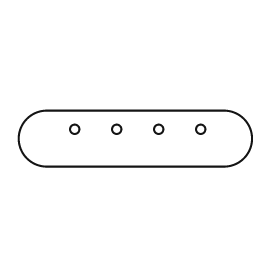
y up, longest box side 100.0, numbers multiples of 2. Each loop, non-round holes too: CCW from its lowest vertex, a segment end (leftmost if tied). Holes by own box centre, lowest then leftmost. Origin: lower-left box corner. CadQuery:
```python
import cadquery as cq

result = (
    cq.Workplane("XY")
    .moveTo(12.0, 0.0)
    .lineTo(88.0, 0.0)
    .threePointArc((100.0, 12.0), (88.0, 24.0))
    .lineTo(12.0, 24.0)
    .threePointArc((0.0, 12.0), (12.0, 0.0))
    .close()
    .moveTo(24.0, 16.0)
    .circle(2.0)
    .moveTo(42.0, 16.0)
    .circle(2.0)
    .moveTo(60.0, 16.0)
    .circle(2.0)
    .moveTo(78.0, 16.0)
    .circle(2.0)
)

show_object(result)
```